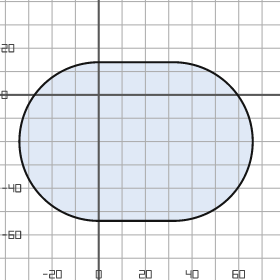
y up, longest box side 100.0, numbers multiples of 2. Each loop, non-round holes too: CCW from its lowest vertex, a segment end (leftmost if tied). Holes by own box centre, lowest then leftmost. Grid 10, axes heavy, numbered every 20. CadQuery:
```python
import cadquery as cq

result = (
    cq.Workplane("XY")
    .moveTo(0.0, -54.0)
    .lineTo(32.0, -54.0)
    .threePointArc((66.0, -20.0), (32.0, 14.0))
    .lineTo(0.0, 14.0)
    .threePointArc((-34.0, -20.0), (0.0, -54.0))
    .close()
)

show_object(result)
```